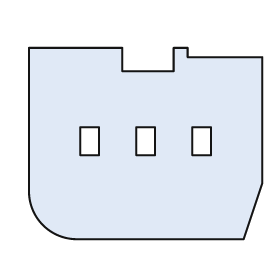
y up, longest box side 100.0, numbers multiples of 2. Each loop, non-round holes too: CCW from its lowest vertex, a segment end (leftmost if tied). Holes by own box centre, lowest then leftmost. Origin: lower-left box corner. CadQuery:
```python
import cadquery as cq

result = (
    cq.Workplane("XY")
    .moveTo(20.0, 0.0)
    .lineTo(92.0, 0.0)
    .lineTo(100.0, 24.0)
    .lineTo(100.0, 78.0)
    .lineTo(68.0, 78.0)
    .lineTo(68.0, 82.0)
    .lineTo(62.0, 82.0)
    .lineTo(62.0, 72.0)
    .lineTo(40.0, 72.0)
    .lineTo(40.0, 82.0)
    .lineTo(0.0, 82.0)
    .lineTo(0.0, 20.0)
    .threePointArc((6.0, 6.0), (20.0, 0.0))
    .close()
    .moveTo(22.0, 36.0)
    .lineTo(30.0, 36.0)
    .lineTo(30.0, 48.0)
    .lineTo(22.0, 48.0)
    .close()
    .moveTo(46.0, 36.0)
    .lineTo(54.0, 36.0)
    .lineTo(54.0, 48.0)
    .lineTo(46.0, 48.0)
    .close()
    .moveTo(70.0, 36.0)
    .lineTo(78.0, 36.0)
    .lineTo(78.0, 48.0)
    .lineTo(70.0, 48.0)
    .close()
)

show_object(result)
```